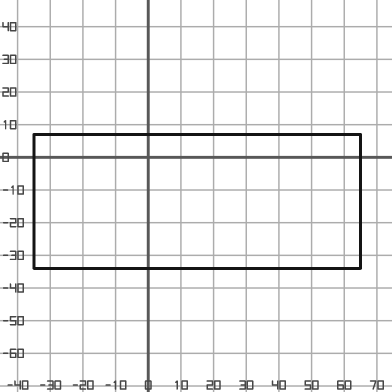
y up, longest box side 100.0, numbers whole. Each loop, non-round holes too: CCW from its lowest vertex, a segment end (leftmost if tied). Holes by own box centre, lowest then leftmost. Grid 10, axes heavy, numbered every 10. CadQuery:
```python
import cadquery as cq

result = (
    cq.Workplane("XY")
    .moveTo(-35.0, -34.0)
    .lineTo(65.0, -34.0)
    .lineTo(65.0, 7.0)
    .lineTo(-35.0, 7.0)
    .close()
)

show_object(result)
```